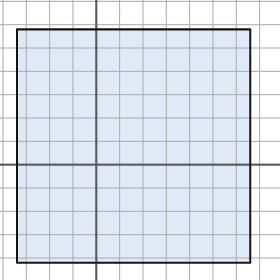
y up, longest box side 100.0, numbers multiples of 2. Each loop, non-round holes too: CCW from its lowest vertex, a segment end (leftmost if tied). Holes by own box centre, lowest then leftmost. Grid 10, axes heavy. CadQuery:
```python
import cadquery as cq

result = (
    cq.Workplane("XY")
    .moveTo(-34.0, -42.0)
    .lineTo(66.0, -42.0)
    .lineTo(66.0, 58.0)
    .lineTo(-34.0, 58.0)
    .close()
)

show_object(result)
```